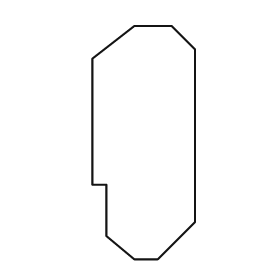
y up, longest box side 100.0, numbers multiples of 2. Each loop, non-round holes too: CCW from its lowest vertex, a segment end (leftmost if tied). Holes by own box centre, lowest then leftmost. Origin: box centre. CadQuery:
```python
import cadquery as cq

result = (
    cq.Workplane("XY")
    .moveTo(-4.0, -50.0)
    .lineTo(6.0, -50.0)
    .lineTo(22.0, -34.0)
    .lineTo(22.0, 40.0)
    .lineTo(12.0, 50.0)
    .lineTo(-4.0, 50.0)
    .lineTo(-22.0, 36.0)
    .lineTo(-22.0, -18.0)
    .lineTo(-16.0, -18.0)
    .lineTo(-16.0, -40.0)
    .close()
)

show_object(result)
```